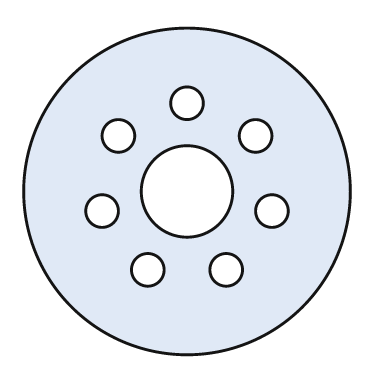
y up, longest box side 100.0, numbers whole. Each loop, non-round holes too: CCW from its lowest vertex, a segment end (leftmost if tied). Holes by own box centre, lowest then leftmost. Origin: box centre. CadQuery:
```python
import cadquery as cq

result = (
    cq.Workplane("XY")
    .moveTo(0.0, 0.0)
    .circle(50.0)
    .moveTo(-12.0, -24.0)
    .circle(5.0)
    .moveTo(12.0, -24.0)
    .circle(5.0)
    .moveTo(-26.0, -6.0)
    .circle(5.0)
    .moveTo(26.0, -6.0)
    .circle(5.0)
    .moveTo(0.0, 0.0)
    .circle(14.0)
    .moveTo(-21.0, 17.0)
    .circle(5.0)
    .moveTo(21.0, 17.0)
    .circle(5.0)
    .moveTo(0.0, 27.0)
    .circle(5.0)
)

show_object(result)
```